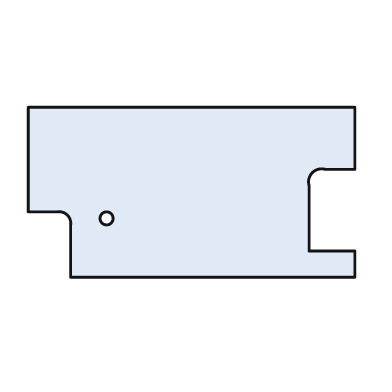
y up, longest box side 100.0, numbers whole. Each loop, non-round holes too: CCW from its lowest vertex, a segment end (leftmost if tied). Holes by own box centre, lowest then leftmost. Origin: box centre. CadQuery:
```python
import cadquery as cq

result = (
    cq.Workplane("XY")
    .moveTo(-37.0, -26.0)
    .lineTo(50.0, -26.0)
    .lineTo(50.0, -18.0)
    .lineTo(36.0, -18.0)
    .lineTo(36.0, 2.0)
    .threePointArc((37.0, 6.0), (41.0, 7.0))
    .lineTo(50.0, 7.0)
    .lineTo(50.0, 26.0)
    .lineTo(-50.0, 26.0)
    .lineTo(-50.0, -6.0)
    .lineTo(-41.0, -6.0)
    .threePointArc((-38.0, -7.0), (-37.0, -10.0))
    .close()
    .moveTo(-26.0, -8.0)
    .circle(2.0)
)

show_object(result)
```